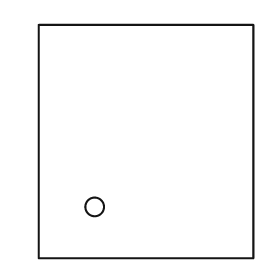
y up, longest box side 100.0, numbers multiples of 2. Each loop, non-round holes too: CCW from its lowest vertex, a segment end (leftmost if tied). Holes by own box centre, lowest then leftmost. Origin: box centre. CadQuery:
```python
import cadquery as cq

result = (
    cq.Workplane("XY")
    .moveTo(-46.0, -50.0)
    .lineTo(46.0, -50.0)
    .lineTo(46.0, 50.0)
    .lineTo(-46.0, 50.0)
    .close()
    .moveTo(-22.0, -28.0)
    .circle(4.0)
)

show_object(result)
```